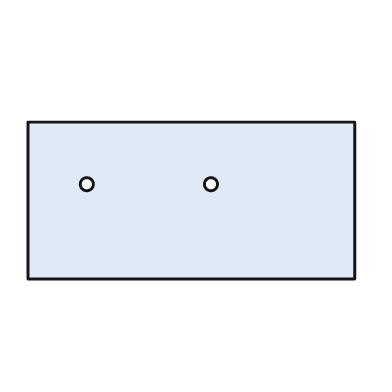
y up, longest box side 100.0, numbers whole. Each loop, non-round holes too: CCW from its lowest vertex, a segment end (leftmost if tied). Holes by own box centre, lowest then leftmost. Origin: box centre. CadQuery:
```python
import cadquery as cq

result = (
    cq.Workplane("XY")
    .moveTo(-50.0, -24.0)
    .lineTo(50.0, -24.0)
    .lineTo(50.0, 24.0)
    .lineTo(-50.0, 24.0)
    .close()
    .moveTo(-32.0, 5.0)
    .circle(2.0)
    .moveTo(6.0, 5.0)
    .circle(2.0)
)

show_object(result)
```